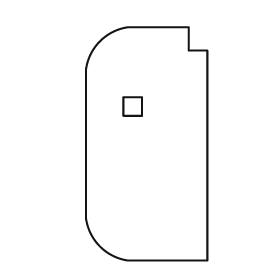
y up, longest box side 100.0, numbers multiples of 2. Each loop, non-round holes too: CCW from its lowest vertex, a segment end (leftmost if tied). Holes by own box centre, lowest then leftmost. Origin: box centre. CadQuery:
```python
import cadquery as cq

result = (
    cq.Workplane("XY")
    .moveTo(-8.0, -50.0)
    .lineTo(26.0, -50.0)
    .lineTo(26.0, 40.0)
    .lineTo(18.0, 40.0)
    .lineTo(18.0, 50.0)
    .lineTo(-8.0, 50.0)
    .threePointArc((-20.0, 44.0), (-26.0, 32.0))
    .lineTo(-26.0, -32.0)
    .threePointArc((-20.0, -44.0), (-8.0, -50.0))
    .close()
    .moveTo(-10.0, 12.0)
    .lineTo(-2.0, 12.0)
    .lineTo(-2.0, 20.0)
    .lineTo(-10.0, 20.0)
    .close()
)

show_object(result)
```